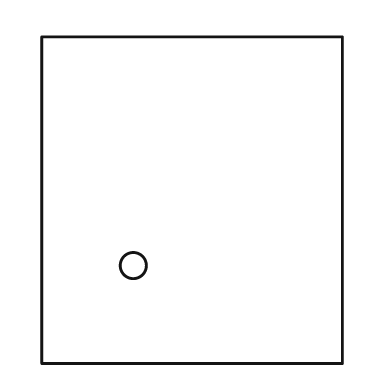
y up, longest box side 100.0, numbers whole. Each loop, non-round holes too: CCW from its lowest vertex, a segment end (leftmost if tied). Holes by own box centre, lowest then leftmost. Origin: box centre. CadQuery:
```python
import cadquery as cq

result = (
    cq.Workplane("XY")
    .moveTo(-46.0, -50.0)
    .lineTo(46.0, -50.0)
    .lineTo(46.0, 50.0)
    .lineTo(-46.0, 50.0)
    .close()
    .moveTo(-18.0, -20.0)
    .circle(4.0)
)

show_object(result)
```